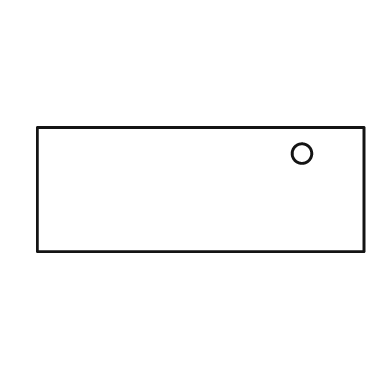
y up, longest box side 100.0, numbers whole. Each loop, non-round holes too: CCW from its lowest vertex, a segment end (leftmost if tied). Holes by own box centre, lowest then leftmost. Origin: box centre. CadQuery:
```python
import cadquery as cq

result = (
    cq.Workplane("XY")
    .moveTo(-50.0, -19.0)
    .lineTo(50.0, -19.0)
    .lineTo(50.0, 19.0)
    .lineTo(-50.0, 19.0)
    .close()
    .moveTo(31.0, 11.0)
    .circle(3.0)
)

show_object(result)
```